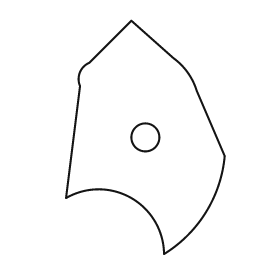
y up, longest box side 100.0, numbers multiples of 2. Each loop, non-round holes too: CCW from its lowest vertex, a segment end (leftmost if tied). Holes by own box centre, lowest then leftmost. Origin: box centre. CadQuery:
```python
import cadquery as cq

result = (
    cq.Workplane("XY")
    .moveTo(8.0, -50.0)
    .threePointArc((26.0, -32.0), (34.0, -8.0))
    .lineTo(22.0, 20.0)
    .threePointArc((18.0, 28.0), (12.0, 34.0))
    .lineTo(-6.0, 50.0)
    .lineTo(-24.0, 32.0)
    .threePointArc((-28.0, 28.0), (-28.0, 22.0))
    .lineTo(-34.0, -26.0)
    .threePointArc((-6.0, -26.0), (8.0, -50.0))
    .close()
    .moveTo(0.0, 0.0)
    .circle(6.0)
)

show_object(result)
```